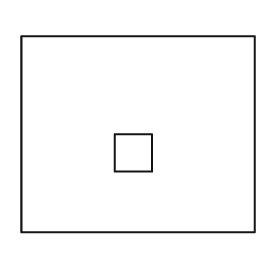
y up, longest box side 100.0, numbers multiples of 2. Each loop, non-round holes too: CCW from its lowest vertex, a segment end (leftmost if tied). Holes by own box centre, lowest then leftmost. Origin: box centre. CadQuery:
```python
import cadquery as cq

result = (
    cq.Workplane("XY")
    .moveTo(-50.0, -42.0)
    .lineTo(50.0, -42.0)
    .lineTo(50.0, 42.0)
    .lineTo(-50.0, 42.0)
    .close()
    .moveTo(-10.0, -16.0)
    .lineTo(6.0, -16.0)
    .lineTo(6.0, 0.0)
    .lineTo(-10.0, 0.0)
    .close()
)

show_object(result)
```